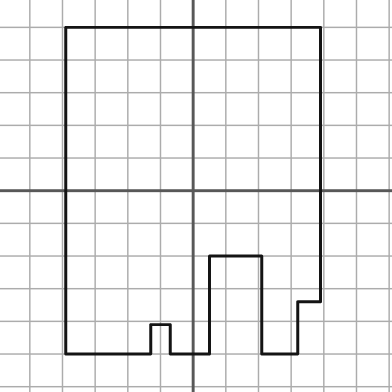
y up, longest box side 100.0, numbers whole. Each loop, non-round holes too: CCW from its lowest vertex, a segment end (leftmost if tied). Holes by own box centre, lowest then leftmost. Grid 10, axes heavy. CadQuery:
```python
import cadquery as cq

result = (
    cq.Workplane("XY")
    .moveTo(-39.0, -50.0)
    .lineTo(-13.0, -50.0)
    .lineTo(-13.0, -41.0)
    .lineTo(-7.0, -41.0)
    .lineTo(-7.0, -50.0)
    .lineTo(5.0, -50.0)
    .lineTo(5.0, -20.0)
    .lineTo(21.0, -20.0)
    .lineTo(21.0, -50.0)
    .lineTo(32.0, -50.0)
    .lineTo(32.0, -34.0)
    .lineTo(39.0, -34.0)
    .lineTo(39.0, 50.0)
    .lineTo(-39.0, 50.0)
    .close()
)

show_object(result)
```